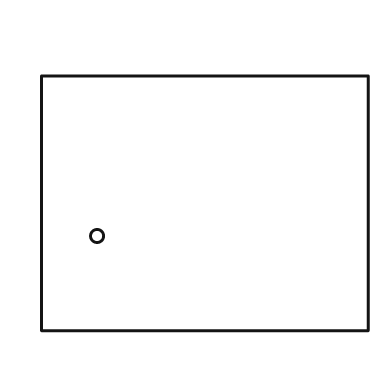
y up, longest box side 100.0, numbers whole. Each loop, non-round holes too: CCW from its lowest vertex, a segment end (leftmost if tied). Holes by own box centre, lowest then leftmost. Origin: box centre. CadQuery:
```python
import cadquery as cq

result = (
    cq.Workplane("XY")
    .moveTo(-50.0, -39.0)
    .lineTo(50.0, -39.0)
    .lineTo(50.0, 39.0)
    .lineTo(-50.0, 39.0)
    .close()
    .moveTo(-33.0, -10.0)
    .circle(2.0)
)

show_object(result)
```